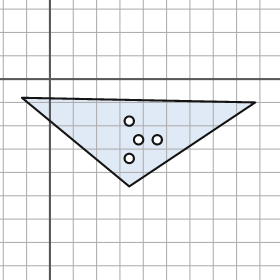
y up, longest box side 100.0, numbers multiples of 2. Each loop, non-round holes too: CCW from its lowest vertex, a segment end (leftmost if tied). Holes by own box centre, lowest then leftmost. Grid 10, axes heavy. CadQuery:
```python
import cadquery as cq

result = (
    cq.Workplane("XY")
    .moveTo(34.0, -46.0)
    .lineTo(88.0, -10.0)
    .lineTo(-12.0, -8.0)
    .close()
    .moveTo(34.0, -34.0)
    .circle(2.0)
    .moveTo(38.0, -26.0)
    .circle(2.0)
    .moveTo(46.0, -26.0)
    .circle(2.0)
    .moveTo(34.0, -18.0)
    .circle(2.0)
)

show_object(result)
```